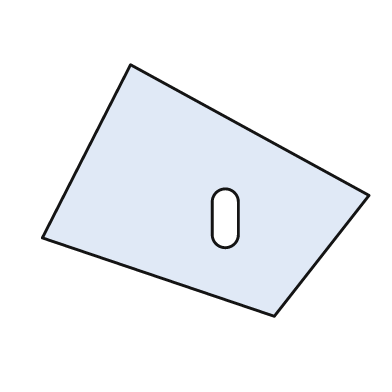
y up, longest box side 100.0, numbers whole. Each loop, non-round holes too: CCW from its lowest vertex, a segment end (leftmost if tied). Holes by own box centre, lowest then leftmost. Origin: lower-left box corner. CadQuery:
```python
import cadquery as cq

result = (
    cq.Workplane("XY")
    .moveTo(71.0, 0.0)
    .lineTo(100.0, 37.0)
    .lineTo(27.0, 77.0)
    .lineTo(0.0, 24.0)
    .close()
    .moveTo(52.0, 25.0)
    .threePointArc((56.0, 21.0), (60.0, 25.0))
    .lineTo(60.0, 35.0)
    .threePointArc((56.0, 39.0), (52.0, 35.0))
    .close()
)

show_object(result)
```